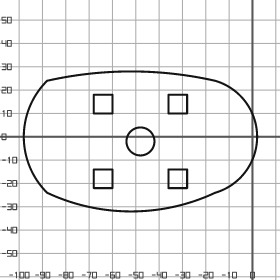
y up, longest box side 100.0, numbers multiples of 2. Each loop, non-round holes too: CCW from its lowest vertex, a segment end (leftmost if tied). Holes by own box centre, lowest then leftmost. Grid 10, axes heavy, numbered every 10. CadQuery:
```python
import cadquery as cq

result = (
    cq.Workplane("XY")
    .moveTo(-88.0, -24.0)
    .threePointArc((-52.0, -32.0), (-16.0, -24.0))
    .threePointArc((2.0, 0.0), (-16.0, 24.0))
    .threePointArc((-52.0, 28.0), (-88.0, 24.0))
    .threePointArc((-98.0, 0.0), (-88.0, -24.0))
    .close()
    .moveTo(-68.0, -22.0)
    .lineTo(-60.0, -22.0)
    .lineTo(-60.0, -14.0)
    .lineTo(-68.0, -14.0)
    .close()
    .moveTo(-36.0, -22.0)
    .lineTo(-28.0, -22.0)
    .lineTo(-28.0, -14.0)
    .lineTo(-36.0, -14.0)
    .close()
    .moveTo(-48.0, -2.0)
    .circle(6.0)
    .moveTo(-68.0, 10.0)
    .lineTo(-60.0, 10.0)
    .lineTo(-60.0, 18.0)
    .lineTo(-68.0, 18.0)
    .close()
    .moveTo(-36.0, 10.0)
    .lineTo(-28.0, 10.0)
    .lineTo(-28.0, 18.0)
    .lineTo(-36.0, 18.0)
    .close()
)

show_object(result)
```